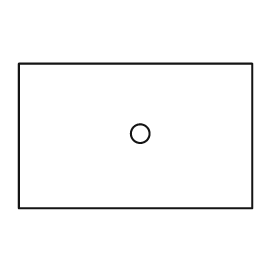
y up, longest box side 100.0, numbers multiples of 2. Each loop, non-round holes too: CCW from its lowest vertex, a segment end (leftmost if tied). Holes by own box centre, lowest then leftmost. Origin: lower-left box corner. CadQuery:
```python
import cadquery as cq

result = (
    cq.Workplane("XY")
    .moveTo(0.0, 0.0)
    .lineTo(100.0, 0.0)
    .lineTo(100.0, 62.0)
    .lineTo(0.0, 62.0)
    .close()
    .moveTo(52.0, 32.0)
    .circle(4.0)
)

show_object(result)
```